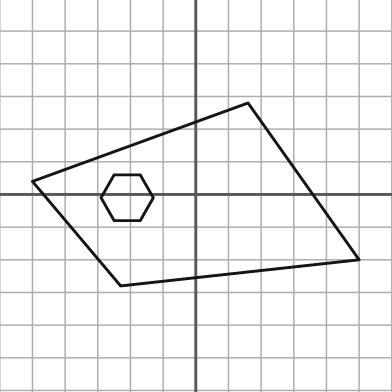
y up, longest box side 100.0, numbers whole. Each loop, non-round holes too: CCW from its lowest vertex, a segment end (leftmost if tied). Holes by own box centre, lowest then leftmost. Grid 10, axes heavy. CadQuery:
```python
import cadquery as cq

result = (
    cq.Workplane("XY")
    .moveTo(-23.0, -28.0)
    .lineTo(50.0, -20.0)
    .lineTo(16.0, 28.0)
    .lineTo(-50.0, 4.0)
    .close()
    .moveTo(-25.0, -8.0)
    .lineTo(-17.0, -8.0)
    .lineTo(-13.0, -1.0)
    .lineTo(-17.0, 6.0)
    .lineTo(-25.0, 6.0)
    .lineTo(-29.0, -1.0)
    .close()
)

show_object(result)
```